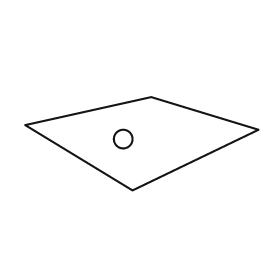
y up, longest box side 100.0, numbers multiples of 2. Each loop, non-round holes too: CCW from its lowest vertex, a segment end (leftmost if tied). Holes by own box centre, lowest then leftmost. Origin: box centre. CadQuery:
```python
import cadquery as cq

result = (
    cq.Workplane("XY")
    .moveTo(-4.0, -20.0)
    .lineTo(50.0, 6.0)
    .lineTo(4.0, 20.0)
    .lineTo(-50.0, 8.0)
    .close()
    .moveTo(-8.0, 2.0)
    .circle(4.0)
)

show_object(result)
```